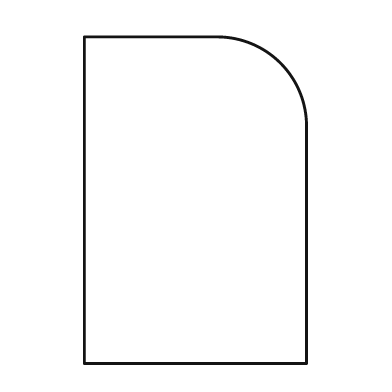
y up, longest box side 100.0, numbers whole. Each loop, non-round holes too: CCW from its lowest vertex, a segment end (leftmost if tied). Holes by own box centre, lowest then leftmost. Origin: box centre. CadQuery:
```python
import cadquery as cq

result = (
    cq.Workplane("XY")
    .moveTo(-34.0, -50.0)
    .lineTo(34.0, -50.0)
    .lineTo(34.0, 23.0)
    .threePointArc((26.0, 42.0), (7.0, 50.0))
    .lineTo(-34.0, 50.0)
    .close()
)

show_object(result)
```